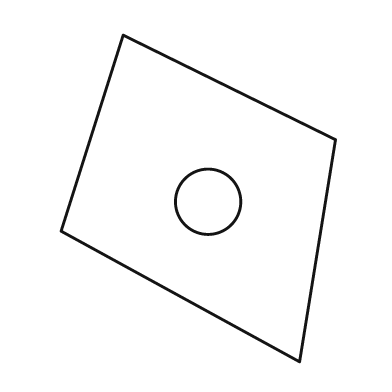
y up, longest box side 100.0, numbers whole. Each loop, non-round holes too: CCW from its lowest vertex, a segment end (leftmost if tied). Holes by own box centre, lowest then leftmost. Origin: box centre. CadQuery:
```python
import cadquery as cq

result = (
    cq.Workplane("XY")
    .moveTo(31.0, -50.0)
    .lineTo(42.0, 18.0)
    .lineTo(-23.0, 50.0)
    .lineTo(-42.0, -10.0)
    .close()
    .moveTo(3.0, -1.0)
    .circle(10.0)
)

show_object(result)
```